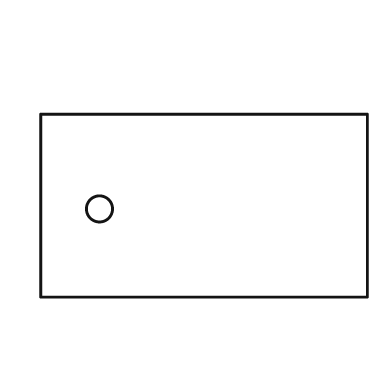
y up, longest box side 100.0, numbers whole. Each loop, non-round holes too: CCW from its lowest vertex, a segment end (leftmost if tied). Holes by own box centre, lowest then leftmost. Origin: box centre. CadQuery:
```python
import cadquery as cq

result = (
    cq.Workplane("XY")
    .moveTo(-50.0, -28.0)
    .lineTo(50.0, -28.0)
    .lineTo(50.0, 28.0)
    .lineTo(-50.0, 28.0)
    .close()
    .moveTo(-32.0, -1.0)
    .circle(4.0)
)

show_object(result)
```